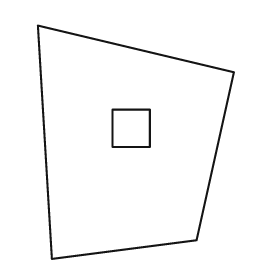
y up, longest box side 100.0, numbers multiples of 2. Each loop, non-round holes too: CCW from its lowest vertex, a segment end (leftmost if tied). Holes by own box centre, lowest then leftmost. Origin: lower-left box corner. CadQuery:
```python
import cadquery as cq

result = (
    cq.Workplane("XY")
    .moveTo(6.0, 0.0)
    .lineTo(68.0, 8.0)
    .lineTo(84.0, 80.0)
    .lineTo(0.0, 100.0)
    .close()
    .moveTo(32.0, 48.0)
    .lineTo(48.0, 48.0)
    .lineTo(48.0, 64.0)
    .lineTo(32.0, 64.0)
    .close()
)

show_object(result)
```